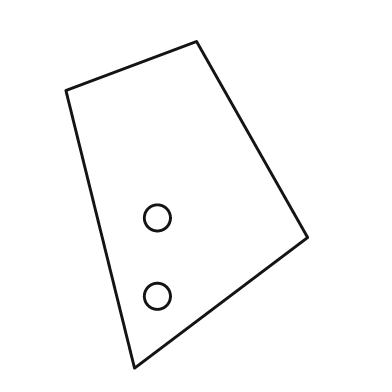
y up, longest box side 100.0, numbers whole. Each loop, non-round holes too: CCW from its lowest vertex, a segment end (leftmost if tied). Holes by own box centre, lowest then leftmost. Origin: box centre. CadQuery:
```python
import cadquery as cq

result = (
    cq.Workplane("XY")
    .moveTo(-16.0, -50.0)
    .lineTo(37.0, -10.0)
    .lineTo(3.0, 50.0)
    .lineTo(-37.0, 35.0)
    .close()
    .moveTo(-9.0, -28.0)
    .circle(4.0)
    .moveTo(-9.0, -4.0)
    .circle(4.0)
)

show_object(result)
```